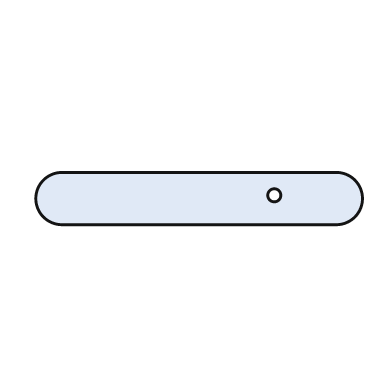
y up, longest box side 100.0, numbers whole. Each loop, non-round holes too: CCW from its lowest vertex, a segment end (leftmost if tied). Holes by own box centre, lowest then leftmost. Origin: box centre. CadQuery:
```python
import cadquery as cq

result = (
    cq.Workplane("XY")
    .moveTo(-42.0, -8.0)
    .lineTo(42.0, -8.0)
    .threePointArc((50.0, 0.0), (42.0, 8.0))
    .lineTo(-42.0, 8.0)
    .threePointArc((-50.0, 0.0), (-42.0, -8.0))
    .close()
    .moveTo(23.0, 1.0)
    .circle(2.0)
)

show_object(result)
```